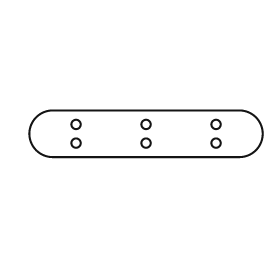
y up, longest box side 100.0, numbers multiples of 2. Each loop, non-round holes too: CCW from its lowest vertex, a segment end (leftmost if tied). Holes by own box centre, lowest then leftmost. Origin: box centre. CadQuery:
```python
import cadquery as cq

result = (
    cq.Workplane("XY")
    .moveTo(-40.0, -10.0)
    .lineTo(40.0, -10.0)
    .threePointArc((50.0, 0.0), (40.0, 10.0))
    .lineTo(-40.0, 10.0)
    .threePointArc((-50.0, 0.0), (-40.0, -10.0))
    .close()
    .moveTo(-30.0, -4.0)
    .circle(2.0)
    .moveTo(0.0, -4.0)
    .circle(2.0)
    .moveTo(30.0, -4.0)
    .circle(2.0)
    .moveTo(-30.0, 4.0)
    .circle(2.0)
    .moveTo(0.0, 4.0)
    .circle(2.0)
    .moveTo(30.0, 4.0)
    .circle(2.0)
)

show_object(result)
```